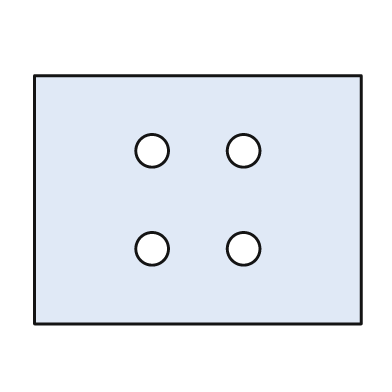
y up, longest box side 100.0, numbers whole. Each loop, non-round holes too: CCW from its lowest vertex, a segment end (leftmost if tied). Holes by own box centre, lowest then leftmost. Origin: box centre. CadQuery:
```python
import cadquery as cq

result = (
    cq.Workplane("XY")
    .moveTo(-50.0, -38.0)
    .lineTo(50.0, -38.0)
    .lineTo(50.0, 38.0)
    .lineTo(-50.0, 38.0)
    .close()
    .moveTo(-14.0, -15.0)
    .circle(5.0)
    .moveTo(14.0, -15.0)
    .circle(5.0)
    .moveTo(-14.0, 15.0)
    .circle(5.0)
    .moveTo(14.0, 15.0)
    .circle(5.0)
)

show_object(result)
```